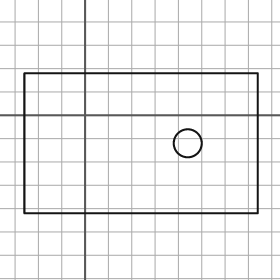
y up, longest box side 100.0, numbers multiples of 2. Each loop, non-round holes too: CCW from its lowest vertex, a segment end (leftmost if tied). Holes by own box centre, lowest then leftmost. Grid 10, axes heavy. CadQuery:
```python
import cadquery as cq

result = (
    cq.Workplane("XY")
    .moveTo(-26.0, -42.0)
    .lineTo(74.0, -42.0)
    .lineTo(74.0, 18.0)
    .lineTo(-26.0, 18.0)
    .close()
    .moveTo(44.0, -12.0)
    .circle(6.0)
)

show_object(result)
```